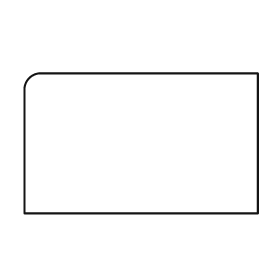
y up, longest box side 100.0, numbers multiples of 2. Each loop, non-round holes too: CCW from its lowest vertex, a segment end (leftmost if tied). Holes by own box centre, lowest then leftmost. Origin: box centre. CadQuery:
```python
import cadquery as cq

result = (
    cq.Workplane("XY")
    .moveTo(-50.0, -30.0)
    .lineTo(50.0, -30.0)
    .lineTo(50.0, 30.0)
    .lineTo(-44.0, 30.0)
    .threePointArc((-48.0, 28.0), (-50.0, 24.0))
    .close()
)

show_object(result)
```